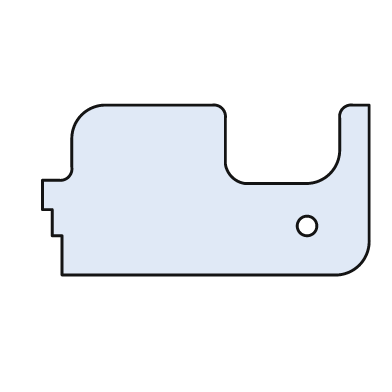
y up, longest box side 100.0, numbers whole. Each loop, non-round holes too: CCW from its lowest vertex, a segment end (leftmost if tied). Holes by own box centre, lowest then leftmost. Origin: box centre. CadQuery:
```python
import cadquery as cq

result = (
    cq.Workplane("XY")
    .moveTo(-44.0, -26.0)
    .lineTo(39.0, -26.0)
    .threePointArc((47.0, -23.0), (50.0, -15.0))
    .lineTo(50.0, 26.0)
    .lineTo(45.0, 26.0)
    .threePointArc((42.0, 25.0), (41.0, 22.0))
    .lineTo(41.0, 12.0)
    .threePointArc((38.0, 5.0), (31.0, 2.0))
    .lineTo(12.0, 2.0)
    .threePointArc((8.0, 4.0), (6.0, 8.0))
    .lineTo(6.0, 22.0)
    .threePointArc((5.0, 25.0), (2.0, 26.0))
    .lineTo(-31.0, 26.0)
    .threePointArc((-38.0, 23.0), (-41.0, 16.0))
    .lineTo(-41.0, 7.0)
    .threePointArc((-42.0, 4.0), (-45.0, 3.0))
    .lineTo(-50.0, 3.0)
    .lineTo(-50.0, -6.0)
    .lineTo(-47.0, -6.0)
    .lineTo(-47.0, -14.0)
    .lineTo(-44.0, -14.0)
    .close()
    .moveTo(31.0, -11.0)
    .circle(3.0)
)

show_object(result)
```